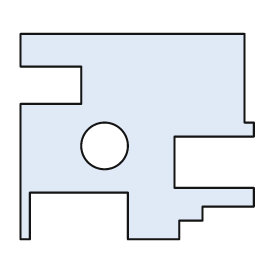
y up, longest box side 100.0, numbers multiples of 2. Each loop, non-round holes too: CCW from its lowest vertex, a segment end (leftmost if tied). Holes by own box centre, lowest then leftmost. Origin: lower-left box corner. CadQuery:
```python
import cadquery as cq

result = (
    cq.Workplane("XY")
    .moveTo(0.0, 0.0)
    .lineTo(4.0, 0.0)
    .lineTo(4.0, 20.0)
    .lineTo(46.0, 20.0)
    .lineTo(46.0, 0.0)
    .lineTo(68.0, 0.0)
    .lineTo(68.0, 8.0)
    .lineTo(78.0, 8.0)
    .lineTo(78.0, 14.0)
    .lineTo(100.0, 14.0)
    .lineTo(100.0, 22.0)
    .lineTo(66.0, 22.0)
    .lineTo(66.0, 44.0)
    .lineTo(100.0, 44.0)
    .lineTo(100.0, 50.0)
    .lineTo(96.0, 50.0)
    .lineTo(96.0, 88.0)
    .lineTo(0.0, 88.0)
    .lineTo(0.0, 74.0)
    .lineTo(26.0, 74.0)
    .lineTo(26.0, 58.0)
    .lineTo(0.0, 58.0)
    .close()
    .moveTo(36.0, 40.0)
    .circle(10.0)
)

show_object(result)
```